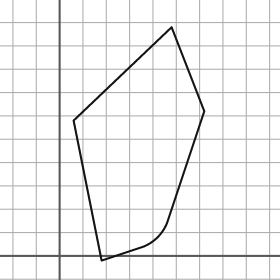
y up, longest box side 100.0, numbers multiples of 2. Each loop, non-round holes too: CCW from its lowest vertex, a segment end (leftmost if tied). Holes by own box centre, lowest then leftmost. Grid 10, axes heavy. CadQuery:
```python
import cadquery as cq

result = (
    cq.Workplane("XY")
    .moveTo(18.0, -2.0)
    .lineTo(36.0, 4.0)
    .threePointArc((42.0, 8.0), (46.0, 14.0))
    .lineTo(62.0, 62.0)
    .lineTo(48.0, 98.0)
    .lineTo(6.0, 58.0)
    .close()
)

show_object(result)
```